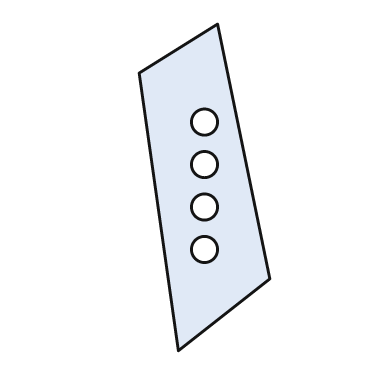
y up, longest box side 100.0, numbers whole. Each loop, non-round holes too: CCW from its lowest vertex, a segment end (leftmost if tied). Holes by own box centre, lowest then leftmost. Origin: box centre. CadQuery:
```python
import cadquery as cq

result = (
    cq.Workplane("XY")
    .moveTo(-8.0, -50.0)
    .lineTo(20.0, -28.0)
    .lineTo(4.0, 50.0)
    .lineTo(-20.0, 35.0)
    .close()
    .moveTo(0.0, -19.0)
    .circle(4.0)
    .moveTo(0.0, -6.0)
    .circle(4.0)
    .moveTo(0.0, 7.0)
    .circle(4.0)
    .moveTo(0.0, 20.0)
    .circle(4.0)
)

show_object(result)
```